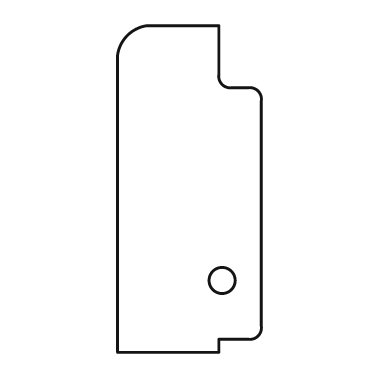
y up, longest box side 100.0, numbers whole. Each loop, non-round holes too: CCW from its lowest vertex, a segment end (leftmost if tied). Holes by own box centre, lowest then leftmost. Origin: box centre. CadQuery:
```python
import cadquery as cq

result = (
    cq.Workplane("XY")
    .moveTo(-22.0, -50.0)
    .lineTo(9.0, -50.0)
    .lineTo(9.0, -46.0)
    .lineTo(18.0, -46.0)
    .threePointArc((21.0, -45.0), (22.0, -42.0))
    .lineTo(22.0, 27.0)
    .threePointArc((21.0, 30.0), (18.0, 31.0))
    .lineTo(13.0, 31.0)
    .threePointArc((10.0, 32.0), (9.0, 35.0))
    .lineTo(9.0, 50.0)
    .lineTo(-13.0, 50.0)
    .threePointArc((-19.0, 47.0), (-22.0, 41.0))
    .close()
    .moveTo(10.0, -28.0)
    .circle(4.0)
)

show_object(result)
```